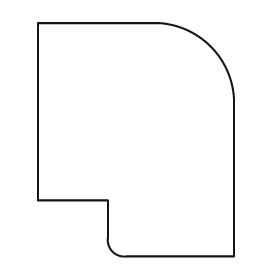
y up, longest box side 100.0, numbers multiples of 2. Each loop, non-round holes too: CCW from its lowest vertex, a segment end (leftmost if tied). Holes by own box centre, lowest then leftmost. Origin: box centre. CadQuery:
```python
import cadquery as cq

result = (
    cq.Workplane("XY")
    .moveTo(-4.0, -50.0)
    .lineTo(42.0, -50.0)
    .lineTo(42.0, 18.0)
    .threePointArc((32.0, 40.0), (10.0, 50.0))
    .lineTo(-42.0, 50.0)
    .lineTo(-42.0, -26.0)
    .lineTo(-12.0, -26.0)
    .lineTo(-12.0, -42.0)
    .threePointArc((-10.0, -48.0), (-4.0, -50.0))
    .close()
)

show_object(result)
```